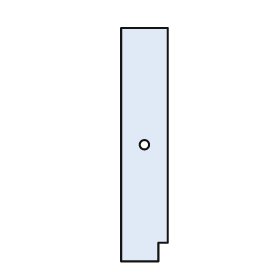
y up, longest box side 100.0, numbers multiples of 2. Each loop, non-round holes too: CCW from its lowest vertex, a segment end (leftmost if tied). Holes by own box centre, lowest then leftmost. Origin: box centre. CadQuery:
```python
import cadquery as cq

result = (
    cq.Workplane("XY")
    .moveTo(-10.0, -50.0)
    .lineTo(6.0, -50.0)
    .lineTo(6.0, -42.0)
    .lineTo(10.0, -42.0)
    .lineTo(10.0, 50.0)
    .lineTo(-10.0, 50.0)
    .close()
    .moveTo(0.0, 0.0)
    .circle(2.0)
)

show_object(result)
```